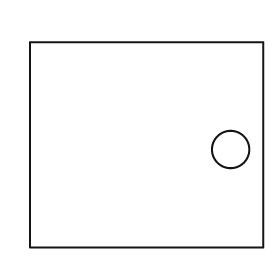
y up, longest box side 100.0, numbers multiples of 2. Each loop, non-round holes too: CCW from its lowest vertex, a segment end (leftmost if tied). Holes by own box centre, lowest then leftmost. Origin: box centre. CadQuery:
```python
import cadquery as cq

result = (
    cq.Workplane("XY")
    .moveTo(-50.0, -44.0)
    .lineTo(50.0, -44.0)
    .lineTo(50.0, 44.0)
    .lineTo(-50.0, 44.0)
    .close()
    .moveTo(36.0, -2.0)
    .circle(8.0)
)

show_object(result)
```